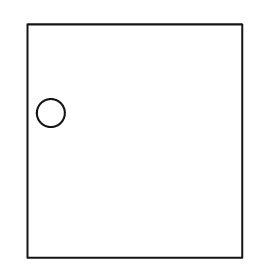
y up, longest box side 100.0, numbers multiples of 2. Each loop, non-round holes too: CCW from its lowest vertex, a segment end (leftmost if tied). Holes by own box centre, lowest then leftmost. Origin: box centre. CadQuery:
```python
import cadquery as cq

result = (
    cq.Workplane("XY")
    .moveTo(-46.0, -50.0)
    .lineTo(46.0, -50.0)
    .lineTo(46.0, 50.0)
    .lineTo(-46.0, 50.0)
    .close()
    .moveTo(-36.0, 12.0)
    .circle(6.0)
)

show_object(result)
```